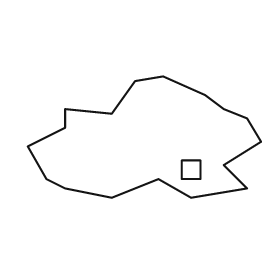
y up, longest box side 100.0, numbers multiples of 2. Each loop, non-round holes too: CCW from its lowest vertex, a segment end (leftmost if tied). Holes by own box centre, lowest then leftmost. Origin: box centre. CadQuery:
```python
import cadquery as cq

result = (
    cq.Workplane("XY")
    .moveTo(-14.0, -26.0)
    .lineTo(6.0, -18.0)
    .lineTo(20.0, -26.0)
    .lineTo(44.0, -22.0)
    .lineTo(34.0, -12.0)
    .lineTo(50.0, -2.0)
    .lineTo(44.0, 8.0)
    .lineTo(34.0, 12.0)
    .lineTo(26.0, 18.0)
    .lineTo(8.0, 26.0)
    .lineTo(-4.0, 24.0)
    .lineTo(-14.0, 10.0)
    .lineTo(-34.0, 12.0)
    .lineTo(-34.0, 4.0)
    .lineTo(-50.0, -4.0)
    .lineTo(-42.0, -18.0)
    .lineTo(-34.0, -22.0)
    .close()
    .moveTo(16.0, -18.0)
    .lineTo(24.0, -18.0)
    .lineTo(24.0, -10.0)
    .lineTo(16.0, -10.0)
    .close()
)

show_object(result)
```